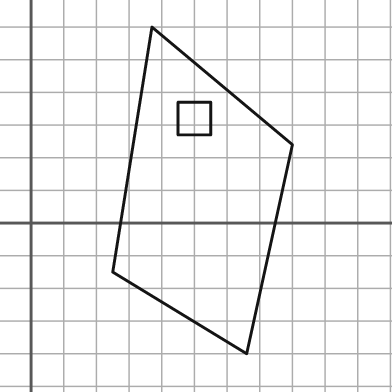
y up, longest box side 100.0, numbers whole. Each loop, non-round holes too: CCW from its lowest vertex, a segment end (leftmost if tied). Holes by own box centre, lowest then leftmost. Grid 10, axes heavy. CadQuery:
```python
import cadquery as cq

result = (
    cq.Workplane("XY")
    .moveTo(66.0, -40.0)
    .lineTo(80.0, 24.0)
    .lineTo(37.0, 60.0)
    .lineTo(25.0, -15.0)
    .close()
    .moveTo(45.0, 27.0)
    .lineTo(55.0, 27.0)
    .lineTo(55.0, 37.0)
    .lineTo(45.0, 37.0)
    .close()
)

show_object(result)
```